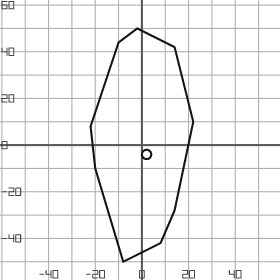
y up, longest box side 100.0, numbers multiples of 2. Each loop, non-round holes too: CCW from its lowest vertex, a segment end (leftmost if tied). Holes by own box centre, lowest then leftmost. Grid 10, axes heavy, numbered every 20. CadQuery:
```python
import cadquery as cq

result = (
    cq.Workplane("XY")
    .moveTo(-8.0, -50.0)
    .lineTo(8.0, -42.0)
    .lineTo(14.0, -28.0)
    .lineTo(22.0, 10.0)
    .lineTo(14.0, 42.0)
    .lineTo(-2.0, 50.0)
    .lineTo(-10.0, 44.0)
    .lineTo(-22.0, 8.0)
    .lineTo(-20.0, -10.0)
    .close()
    .moveTo(2.0, -4.0)
    .circle(2.0)
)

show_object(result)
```